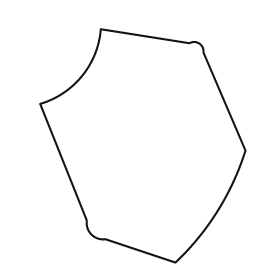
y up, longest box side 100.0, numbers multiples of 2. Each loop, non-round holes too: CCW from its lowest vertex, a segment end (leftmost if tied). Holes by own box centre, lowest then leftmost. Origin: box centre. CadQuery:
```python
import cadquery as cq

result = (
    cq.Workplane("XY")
    .moveTo(14.0, -50.0)
    .threePointArc((32.0, -28.0), (44.0, -2.0))
    .lineTo(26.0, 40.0)
    .threePointArc((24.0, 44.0), (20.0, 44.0))
    .lineTo(-18.0, 50.0)
    .threePointArc((-26.0, 30.0), (-44.0, 18.0))
    .lineTo(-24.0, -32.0)
    .threePointArc((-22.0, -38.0), (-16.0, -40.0))
    .close()
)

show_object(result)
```